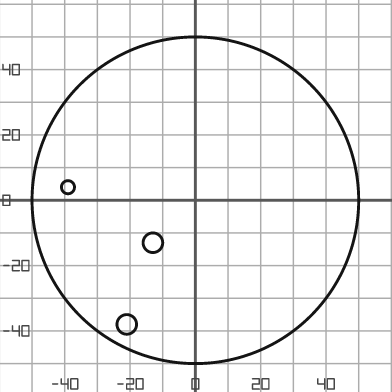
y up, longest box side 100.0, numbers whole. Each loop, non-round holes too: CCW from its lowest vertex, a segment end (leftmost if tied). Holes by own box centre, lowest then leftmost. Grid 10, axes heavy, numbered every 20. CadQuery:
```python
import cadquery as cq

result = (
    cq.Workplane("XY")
    .moveTo(0.0, 0.0)
    .circle(50.0)
    .moveTo(-21.0, -38.0)
    .circle(3.0)
    .moveTo(-13.0, -13.0)
    .circle(3.0)
    .moveTo(-39.0, 4.0)
    .circle(2.0)
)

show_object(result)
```